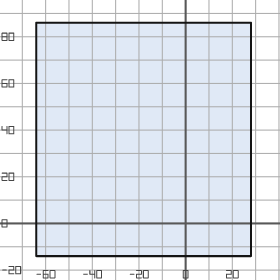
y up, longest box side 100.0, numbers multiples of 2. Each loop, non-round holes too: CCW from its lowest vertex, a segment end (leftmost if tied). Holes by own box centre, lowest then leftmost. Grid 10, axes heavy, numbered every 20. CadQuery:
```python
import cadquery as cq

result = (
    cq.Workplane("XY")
    .moveTo(-64.0, -14.0)
    .lineTo(28.0, -14.0)
    .lineTo(28.0, 86.0)
    .lineTo(-64.0, 86.0)
    .close()
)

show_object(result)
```